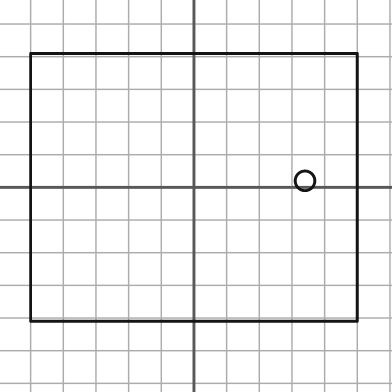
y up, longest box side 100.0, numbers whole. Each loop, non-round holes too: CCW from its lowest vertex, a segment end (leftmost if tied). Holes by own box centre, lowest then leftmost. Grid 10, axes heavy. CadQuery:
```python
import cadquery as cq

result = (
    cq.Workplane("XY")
    .moveTo(-50.0, -41.0)
    .lineTo(50.0, -41.0)
    .lineTo(50.0, 41.0)
    .lineTo(-50.0, 41.0)
    .close()
    .moveTo(34.0, 2.0)
    .circle(3.0)
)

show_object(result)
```